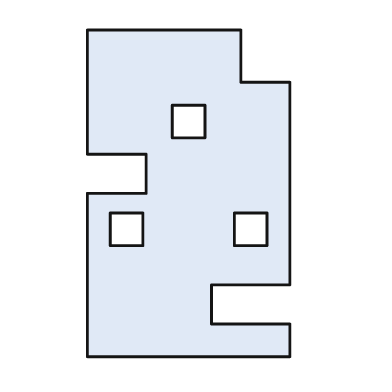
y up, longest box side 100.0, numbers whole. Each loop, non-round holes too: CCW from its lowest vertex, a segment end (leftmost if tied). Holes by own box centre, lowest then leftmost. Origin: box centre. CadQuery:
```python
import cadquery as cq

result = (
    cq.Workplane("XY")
    .moveTo(-31.0, -50.0)
    .lineTo(31.0, -50.0)
    .lineTo(31.0, -40.0)
    .lineTo(7.0, -40.0)
    .lineTo(7.0, -28.0)
    .lineTo(31.0, -28.0)
    .lineTo(31.0, 34.0)
    .lineTo(16.0, 34.0)
    .lineTo(16.0, 50.0)
    .lineTo(-31.0, 50.0)
    .lineTo(-31.0, 12.0)
    .lineTo(-13.0, 12.0)
    .lineTo(-13.0, 0.0)
    .lineTo(-31.0, 0.0)
    .close()
    .moveTo(-24.0, -16.0)
    .lineTo(-14.0, -16.0)
    .lineTo(-14.0, -6.0)
    .lineTo(-24.0, -6.0)
    .close()
    .moveTo(14.0, -16.0)
    .lineTo(24.0, -16.0)
    .lineTo(24.0, -6.0)
    .lineTo(14.0, -6.0)
    .close()
    .moveTo(-5.0, 17.0)
    .lineTo(5.0, 17.0)
    .lineTo(5.0, 27.0)
    .lineTo(-5.0, 27.0)
    .close()
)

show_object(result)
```